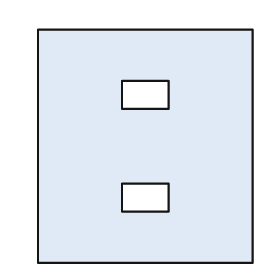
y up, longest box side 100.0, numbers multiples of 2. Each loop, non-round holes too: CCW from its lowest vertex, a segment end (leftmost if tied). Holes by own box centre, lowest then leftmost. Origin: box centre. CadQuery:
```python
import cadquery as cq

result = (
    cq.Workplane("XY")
    .moveTo(-46.0, -50.0)
    .lineTo(46.0, -50.0)
    .lineTo(46.0, 50.0)
    .lineTo(-46.0, 50.0)
    .close()
    .moveTo(-10.0, -28.0)
    .lineTo(10.0, -28.0)
    .lineTo(10.0, -16.0)
    .lineTo(-10.0, -16.0)
    .close()
    .moveTo(-10.0, 16.0)
    .lineTo(10.0, 16.0)
    .lineTo(10.0, 28.0)
    .lineTo(-10.0, 28.0)
    .close()
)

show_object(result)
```